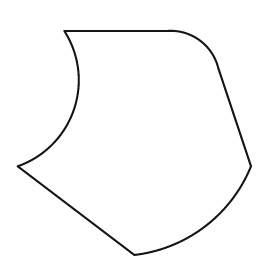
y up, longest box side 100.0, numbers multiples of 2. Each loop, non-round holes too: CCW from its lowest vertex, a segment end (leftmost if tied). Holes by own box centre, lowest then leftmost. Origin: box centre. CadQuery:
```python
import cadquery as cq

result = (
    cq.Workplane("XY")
    .moveTo(0.0, -48.0)
    .threePointArc((30.0, -36.0), (50.0, -10.0))
    .lineTo(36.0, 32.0)
    .threePointArc((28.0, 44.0), (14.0, 48.0))
    .lineTo(-30.0, 48.0)
    .threePointArc((-26.0, 14.0), (-50.0, -10.0))
    .close()
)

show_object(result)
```